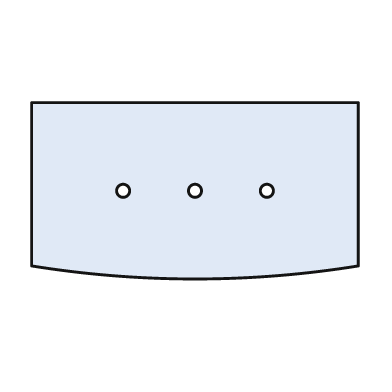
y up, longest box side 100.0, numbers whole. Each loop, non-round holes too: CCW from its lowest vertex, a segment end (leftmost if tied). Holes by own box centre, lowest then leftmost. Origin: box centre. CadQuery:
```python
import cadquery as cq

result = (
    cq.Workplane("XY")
    .moveTo(-50.0, -23.0)
    .threePointArc((0.0, -27.0), (50.0, -23.0))
    .lineTo(50.0, 27.0)
    .lineTo(-50.0, 27.0)
    .close()
    .moveTo(-22.0, 0.0)
    .circle(2.0)
    .moveTo(0.0, 0.0)
    .circle(2.0)
    .moveTo(22.0, 0.0)
    .circle(2.0)
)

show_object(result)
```